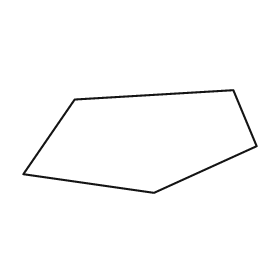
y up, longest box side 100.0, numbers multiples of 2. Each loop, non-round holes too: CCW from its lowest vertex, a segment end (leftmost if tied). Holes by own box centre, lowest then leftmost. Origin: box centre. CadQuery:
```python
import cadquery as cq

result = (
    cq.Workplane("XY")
    .moveTo(6.0, -22.0)
    .lineTo(50.0, -2.0)
    .lineTo(40.0, 22.0)
    .lineTo(-28.0, 18.0)
    .lineTo(-50.0, -14.0)
    .close()
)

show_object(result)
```